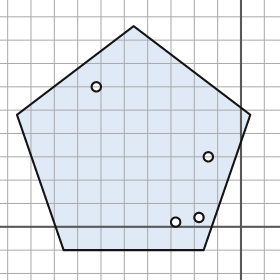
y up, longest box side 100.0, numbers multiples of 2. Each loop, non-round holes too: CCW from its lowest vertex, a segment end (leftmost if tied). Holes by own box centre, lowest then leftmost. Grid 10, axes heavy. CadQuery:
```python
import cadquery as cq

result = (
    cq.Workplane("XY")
    .moveTo(-76.0, -10.0)
    .lineTo(-16.0, -10.0)
    .lineTo(4.0, 48.0)
    .lineTo(-46.0, 86.0)
    .lineTo(-96.0, 48.0)
    .close()
    .moveTo(-28.0, 2.0)
    .circle(2.0)
    .moveTo(-18.0, 4.0)
    .circle(2.0)
    .moveTo(-14.0, 30.0)
    .circle(2.0)
    .moveTo(-62.0, 60.0)
    .circle(2.0)
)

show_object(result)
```